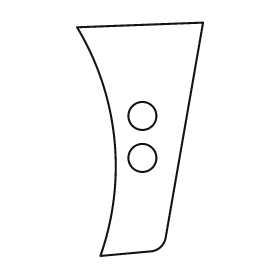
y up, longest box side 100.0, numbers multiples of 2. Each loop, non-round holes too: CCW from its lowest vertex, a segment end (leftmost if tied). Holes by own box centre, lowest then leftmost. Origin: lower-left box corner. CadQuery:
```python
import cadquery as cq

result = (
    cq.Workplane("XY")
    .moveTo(10.0, 0.0)
    .lineTo(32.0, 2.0)
    .threePointArc((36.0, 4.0), (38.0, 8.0))
    .lineTo(54.0, 100.0)
    .lineTo(0.0, 98.0)
    .threePointArc((16.0, 50.0), (10.0, 0.0))
    .close()
    .moveTo(28.0, 42.0)
    .circle(6.0)
    .moveTo(28.0, 60.0)
    .circle(6.0)
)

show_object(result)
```